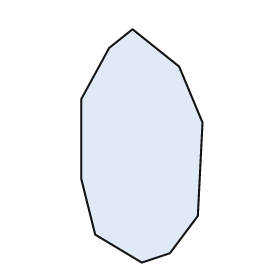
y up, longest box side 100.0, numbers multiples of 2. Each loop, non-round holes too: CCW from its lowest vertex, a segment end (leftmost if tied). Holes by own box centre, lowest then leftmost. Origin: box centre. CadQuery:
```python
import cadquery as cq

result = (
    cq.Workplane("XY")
    .moveTo(0.0, -50.0)
    .lineTo(12.0, -46.0)
    .lineTo(24.0, -30.0)
    .lineTo(26.0, 10.0)
    .lineTo(16.0, 34.0)
    .lineTo(-4.0, 50.0)
    .lineTo(-14.0, 42.0)
    .lineTo(-26.0, 20.0)
    .lineTo(-26.0, -14.0)
    .lineTo(-20.0, -38.0)
    .close()
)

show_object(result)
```